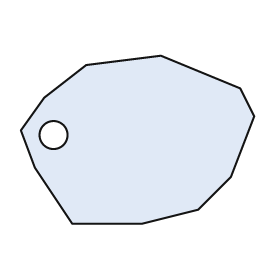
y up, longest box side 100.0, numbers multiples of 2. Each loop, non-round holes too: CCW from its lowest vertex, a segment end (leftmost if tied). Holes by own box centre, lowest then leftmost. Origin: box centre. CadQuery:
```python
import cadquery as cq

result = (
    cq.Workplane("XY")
    .moveTo(-28.0, -36.0)
    .lineTo(2.0, -36.0)
    .lineTo(26.0, -30.0)
    .lineTo(40.0, -16.0)
    .lineTo(50.0, 10.0)
    .lineTo(44.0, 22.0)
    .lineTo(10.0, 36.0)
    .lineTo(-22.0, 32.0)
    .lineTo(-40.0, 18.0)
    .lineTo(-50.0, 4.0)
    .lineTo(-44.0, -12.0)
    .close()
    .moveTo(-36.0, 2.0)
    .circle(6.0)
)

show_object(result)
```